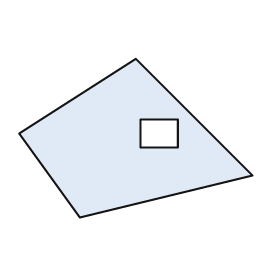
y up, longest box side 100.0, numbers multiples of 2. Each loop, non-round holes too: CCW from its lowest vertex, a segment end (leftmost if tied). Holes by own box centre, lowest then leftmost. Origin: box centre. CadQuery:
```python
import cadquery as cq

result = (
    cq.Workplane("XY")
    .moveTo(-24.0, -34.0)
    .lineTo(50.0, -16.0)
    .lineTo(0.0, 34.0)
    .lineTo(-50.0, 2.0)
    .close()
    .moveTo(2.0, -4.0)
    .lineTo(18.0, -4.0)
    .lineTo(18.0, 8.0)
    .lineTo(2.0, 8.0)
    .close()
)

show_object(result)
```